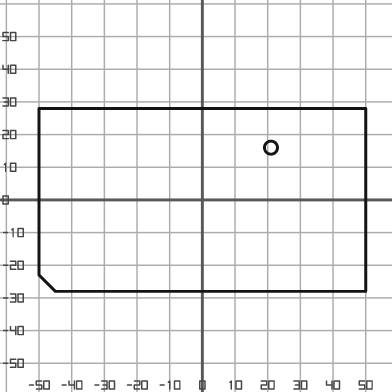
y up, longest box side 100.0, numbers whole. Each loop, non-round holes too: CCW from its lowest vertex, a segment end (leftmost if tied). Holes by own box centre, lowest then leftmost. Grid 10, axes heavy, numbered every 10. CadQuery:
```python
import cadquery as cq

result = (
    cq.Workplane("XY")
    .moveTo(-45.0, -28.0)
    .lineTo(50.0, -28.0)
    .lineTo(50.0, 28.0)
    .lineTo(-50.0, 28.0)
    .lineTo(-50.0, -23.0)
    .close()
    .moveTo(21.0, 16.0)
    .circle(2.0)
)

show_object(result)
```